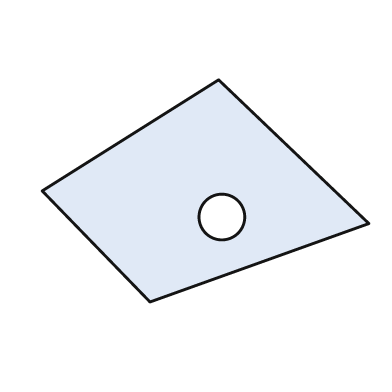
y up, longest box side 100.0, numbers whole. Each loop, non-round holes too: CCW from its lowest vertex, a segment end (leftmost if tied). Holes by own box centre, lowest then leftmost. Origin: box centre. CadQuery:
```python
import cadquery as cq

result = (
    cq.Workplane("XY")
    .moveTo(-17.0, -34.0)
    .lineTo(50.0, -10.0)
    .lineTo(4.0, 34.0)
    .lineTo(-50.0, 0.0)
    .close()
    .moveTo(5.0, -8.0)
    .circle(7.0)
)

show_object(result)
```